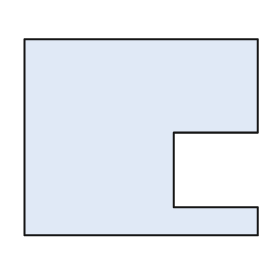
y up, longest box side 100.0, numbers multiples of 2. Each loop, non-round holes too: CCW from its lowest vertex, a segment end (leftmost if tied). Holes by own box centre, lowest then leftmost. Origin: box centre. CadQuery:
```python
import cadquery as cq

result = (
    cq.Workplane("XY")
    .moveTo(-50.0, -42.0)
    .lineTo(50.0, -42.0)
    .lineTo(50.0, -30.0)
    .lineTo(14.0, -30.0)
    .lineTo(14.0, 2.0)
    .lineTo(50.0, 2.0)
    .lineTo(50.0, 42.0)
    .lineTo(-50.0, 42.0)
    .close()
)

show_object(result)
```